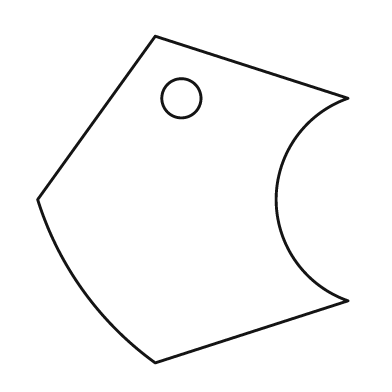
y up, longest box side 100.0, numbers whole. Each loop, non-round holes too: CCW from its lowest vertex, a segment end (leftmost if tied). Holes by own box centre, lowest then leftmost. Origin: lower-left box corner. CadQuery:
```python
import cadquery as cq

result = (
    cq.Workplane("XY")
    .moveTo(36.0, 0.0)
    .lineTo(95.0, 19.0)
    .threePointArc((73.0, 50.0), (95.0, 81.0))
    .lineTo(36.0, 100.0)
    .lineTo(0.0, 50.0)
    .threePointArc((14.0, 22.0), (36.0, 0.0))
    .close()
    .moveTo(44.0, 81.0)
    .circle(6.0)
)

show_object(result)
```